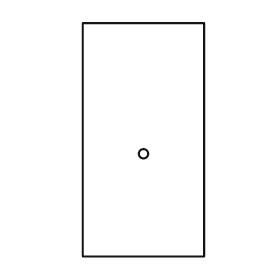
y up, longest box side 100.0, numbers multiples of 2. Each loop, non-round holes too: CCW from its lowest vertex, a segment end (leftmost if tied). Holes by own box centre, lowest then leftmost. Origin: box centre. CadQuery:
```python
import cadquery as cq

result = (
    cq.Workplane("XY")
    .moveTo(-26.0, -50.0)
    .lineTo(26.0, -50.0)
    .lineTo(26.0, 50.0)
    .lineTo(-26.0, 50.0)
    .close()
    .moveTo(0.0, -6.0)
    .circle(2.0)
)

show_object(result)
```